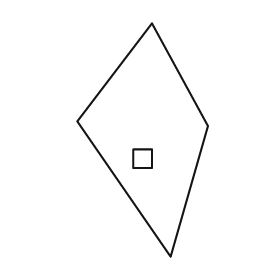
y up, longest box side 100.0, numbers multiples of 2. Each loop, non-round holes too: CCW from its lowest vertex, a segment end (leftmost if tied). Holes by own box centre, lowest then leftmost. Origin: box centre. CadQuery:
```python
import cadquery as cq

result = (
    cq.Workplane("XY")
    .moveTo(12.0, -50.0)
    .lineTo(28.0, 6.0)
    .lineTo(4.0, 50.0)
    .lineTo(-28.0, 8.0)
    .close()
    .moveTo(-4.0, -12.0)
    .lineTo(4.0, -12.0)
    .lineTo(4.0, -4.0)
    .lineTo(-4.0, -4.0)
    .close()
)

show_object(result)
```